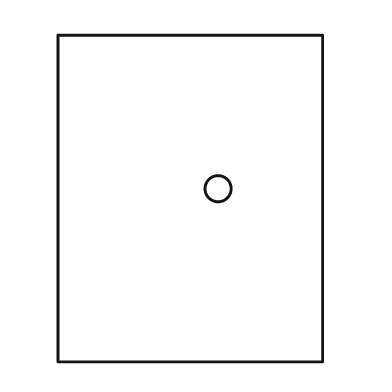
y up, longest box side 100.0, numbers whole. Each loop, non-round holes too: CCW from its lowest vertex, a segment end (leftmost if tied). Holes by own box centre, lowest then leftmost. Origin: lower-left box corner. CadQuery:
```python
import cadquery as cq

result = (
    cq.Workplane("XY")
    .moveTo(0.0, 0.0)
    .lineTo(81.0, 0.0)
    .lineTo(81.0, 100.0)
    .lineTo(0.0, 100.0)
    .close()
    .moveTo(49.0, 53.0)
    .circle(4.0)
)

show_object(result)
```